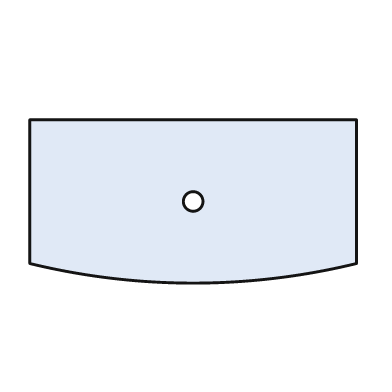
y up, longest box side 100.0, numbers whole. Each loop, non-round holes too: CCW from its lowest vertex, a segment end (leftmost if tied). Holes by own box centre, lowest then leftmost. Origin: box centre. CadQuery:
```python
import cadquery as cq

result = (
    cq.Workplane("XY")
    .moveTo(-50.0, -19.0)
    .threePointArc((0.0, -25.0), (50.0, -19.0))
    .lineTo(50.0, 25.0)
    .lineTo(-50.0, 25.0)
    .close()
    .moveTo(0.0, 0.0)
    .circle(3.0)
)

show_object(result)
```